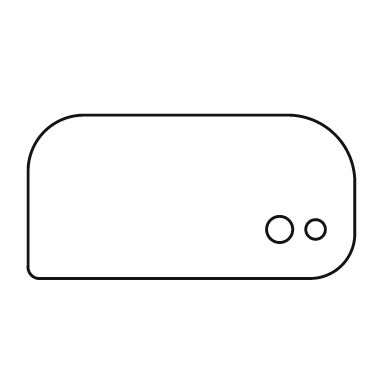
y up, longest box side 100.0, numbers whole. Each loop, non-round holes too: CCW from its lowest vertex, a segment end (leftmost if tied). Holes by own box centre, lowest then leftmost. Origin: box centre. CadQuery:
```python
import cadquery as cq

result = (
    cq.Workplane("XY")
    .moveTo(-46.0, -25.0)
    .lineTo(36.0, -25.0)
    .threePointArc((46.0, -21.0), (50.0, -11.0))
    .lineTo(50.0, 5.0)
    .threePointArc((44.0, 19.0), (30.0, 25.0))
    .lineTo(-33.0, 25.0)
    .threePointArc((-45.0, 20.0), (-50.0, 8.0))
    .lineTo(-50.0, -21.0)
    .threePointArc((-49.0, -24.0), (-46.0, -25.0))
    .close()
    .moveTo(27.0, -10.0)
    .circle(4.0)
    .moveTo(38.0, -10.0)
    .circle(3.0)
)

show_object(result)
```